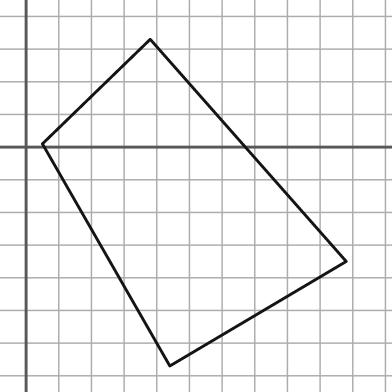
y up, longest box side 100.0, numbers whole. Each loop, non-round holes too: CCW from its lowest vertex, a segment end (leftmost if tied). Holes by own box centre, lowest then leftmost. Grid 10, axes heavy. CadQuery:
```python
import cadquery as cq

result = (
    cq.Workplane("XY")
    .moveTo(44.0, -67.0)
    .lineTo(98.0, -35.0)
    .lineTo(38.0, 33.0)
    .lineTo(5.0, 1.0)
    .close()
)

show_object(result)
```